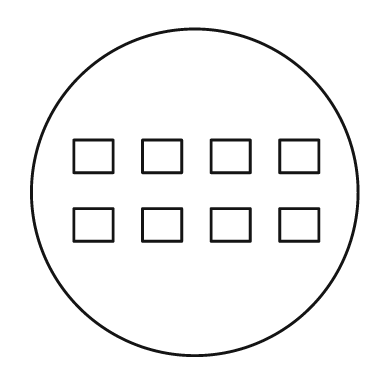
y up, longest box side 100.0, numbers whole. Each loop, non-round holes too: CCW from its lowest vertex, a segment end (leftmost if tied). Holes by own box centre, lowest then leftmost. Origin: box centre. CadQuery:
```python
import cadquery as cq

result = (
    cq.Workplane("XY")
    .moveTo(0.0, 0.0)
    .circle(50.0)
    .moveTo(-37.0, -15.0)
    .lineTo(-25.0, -15.0)
    .lineTo(-25.0, -5.0)
    .lineTo(-37.0, -5.0)
    .close()
    .moveTo(-16.0, -15.0)
    .lineTo(-4.0, -15.0)
    .lineTo(-4.0, -5.0)
    .lineTo(-16.0, -5.0)
    .close()
    .moveTo(5.0, -15.0)
    .lineTo(17.0, -15.0)
    .lineTo(17.0, -5.0)
    .lineTo(5.0, -5.0)
    .close()
    .moveTo(26.0, -15.0)
    .lineTo(38.0, -15.0)
    .lineTo(38.0, -5.0)
    .lineTo(26.0, -5.0)
    .close()
    .moveTo(-37.0, 6.0)
    .lineTo(-25.0, 6.0)
    .lineTo(-25.0, 16.0)
    .lineTo(-37.0, 16.0)
    .close()
    .moveTo(-16.0, 6.0)
    .lineTo(-4.0, 6.0)
    .lineTo(-4.0, 16.0)
    .lineTo(-16.0, 16.0)
    .close()
    .moveTo(5.0, 6.0)
    .lineTo(17.0, 6.0)
    .lineTo(17.0, 16.0)
    .lineTo(5.0, 16.0)
    .close()
    .moveTo(26.0, 6.0)
    .lineTo(38.0, 6.0)
    .lineTo(38.0, 16.0)
    .lineTo(26.0, 16.0)
    .close()
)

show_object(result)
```